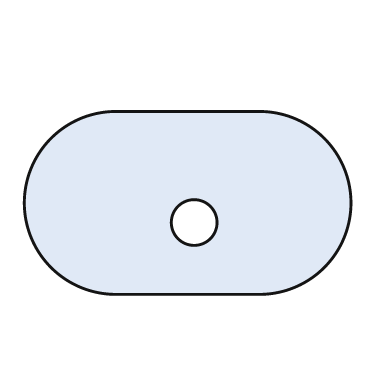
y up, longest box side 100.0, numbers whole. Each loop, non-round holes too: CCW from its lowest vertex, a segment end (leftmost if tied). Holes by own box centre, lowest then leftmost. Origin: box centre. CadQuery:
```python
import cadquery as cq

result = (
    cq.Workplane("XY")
    .moveTo(-22.0, -28.0)
    .lineTo(22.0, -28.0)
    .threePointArc((50.0, 0.0), (22.0, 28.0))
    .lineTo(-22.0, 28.0)
    .threePointArc((-50.0, 0.0), (-22.0, -28.0))
    .close()
    .moveTo(2.0, -6.0)
    .circle(7.0)
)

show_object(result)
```